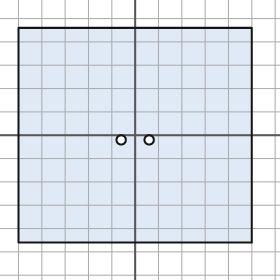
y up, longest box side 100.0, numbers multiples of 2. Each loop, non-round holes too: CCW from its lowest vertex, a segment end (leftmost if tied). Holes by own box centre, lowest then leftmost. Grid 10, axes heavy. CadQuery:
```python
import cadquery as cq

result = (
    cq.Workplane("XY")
    .moveTo(-50.0, -46.0)
    .lineTo(50.0, -46.0)
    .lineTo(50.0, 46.0)
    .lineTo(-50.0, 46.0)
    .close()
    .moveTo(-6.0, -2.0)
    .circle(2.0)
    .moveTo(6.0, -2.0)
    .circle(2.0)
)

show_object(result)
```